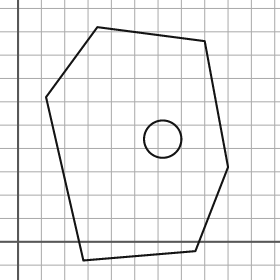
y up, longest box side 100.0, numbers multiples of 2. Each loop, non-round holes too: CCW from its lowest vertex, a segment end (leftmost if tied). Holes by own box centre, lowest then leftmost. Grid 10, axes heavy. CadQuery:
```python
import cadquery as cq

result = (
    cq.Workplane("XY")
    .moveTo(28.0, -8.0)
    .lineTo(76.0, -4.0)
    .lineTo(90.0, 32.0)
    .lineTo(80.0, 86.0)
    .lineTo(34.0, 92.0)
    .lineTo(12.0, 62.0)
    .close()
    .moveTo(62.0, 44.0)
    .circle(8.0)
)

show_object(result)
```